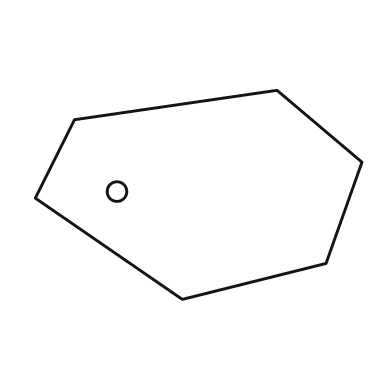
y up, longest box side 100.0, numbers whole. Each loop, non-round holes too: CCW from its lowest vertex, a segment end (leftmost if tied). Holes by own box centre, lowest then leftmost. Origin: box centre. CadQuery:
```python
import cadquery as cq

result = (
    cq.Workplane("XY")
    .moveTo(-5.0, -32.0)
    .lineTo(39.0, -21.0)
    .lineTo(50.0, 10.0)
    .lineTo(24.0, 32.0)
    .lineTo(-38.0, 23.0)
    .lineTo(-50.0, -1.0)
    .close()
    .moveTo(-25.0, 1.0)
    .circle(3.0)
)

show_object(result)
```